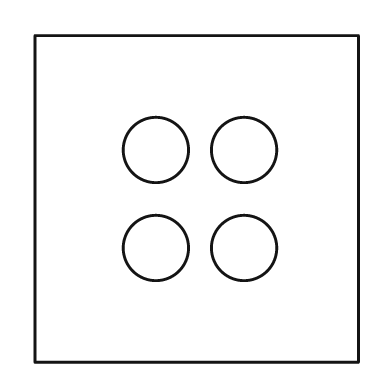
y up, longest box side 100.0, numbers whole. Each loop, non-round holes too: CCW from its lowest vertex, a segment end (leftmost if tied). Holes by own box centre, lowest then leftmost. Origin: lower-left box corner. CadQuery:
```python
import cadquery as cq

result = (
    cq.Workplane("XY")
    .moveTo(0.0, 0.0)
    .lineTo(99.0, 0.0)
    .lineTo(99.0, 100.0)
    .lineTo(0.0, 100.0)
    .close()
    .moveTo(37.0, 35.0)
    .circle(10.0)
    .moveTo(64.0, 35.0)
    .circle(10.0)
    .moveTo(37.0, 65.0)
    .circle(10.0)
    .moveTo(64.0, 65.0)
    .circle(10.0)
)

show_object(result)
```